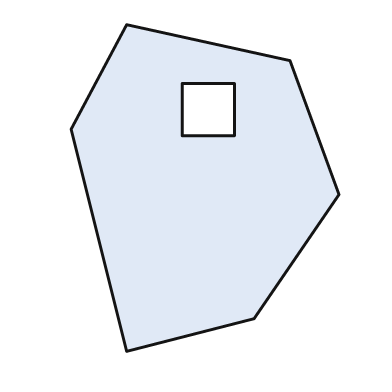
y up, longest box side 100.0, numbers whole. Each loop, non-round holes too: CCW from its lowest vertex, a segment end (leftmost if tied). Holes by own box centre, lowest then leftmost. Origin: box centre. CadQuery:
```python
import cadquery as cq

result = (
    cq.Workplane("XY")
    .moveTo(-24.0, -50.0)
    .lineTo(15.0, -40.0)
    .lineTo(41.0, -2.0)
    .lineTo(26.0, 39.0)
    .lineTo(-24.0, 50.0)
    .lineTo(-41.0, 18.0)
    .close()
    .moveTo(-7.0, 16.0)
    .lineTo(9.0, 16.0)
    .lineTo(9.0, 32.0)
    .lineTo(-7.0, 32.0)
    .close()
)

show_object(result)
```